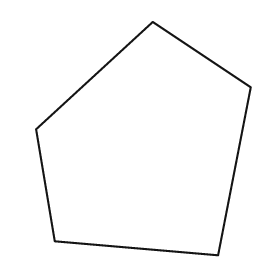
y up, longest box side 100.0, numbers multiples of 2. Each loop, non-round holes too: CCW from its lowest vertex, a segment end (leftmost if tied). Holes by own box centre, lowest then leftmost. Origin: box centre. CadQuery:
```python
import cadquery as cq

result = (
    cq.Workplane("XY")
    .moveTo(32.0, -50.0)
    .lineTo(46.0, 22.0)
    .lineTo(4.0, 50.0)
    .lineTo(-46.0, 4.0)
    .lineTo(-38.0, -44.0)
    .close()
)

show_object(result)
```